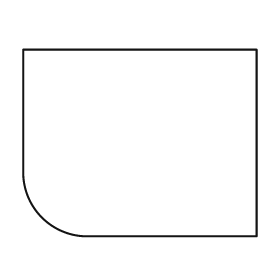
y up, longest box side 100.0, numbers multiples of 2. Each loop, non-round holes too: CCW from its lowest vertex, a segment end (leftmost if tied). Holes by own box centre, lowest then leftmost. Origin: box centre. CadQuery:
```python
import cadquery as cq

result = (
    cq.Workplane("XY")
    .moveTo(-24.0, -40.0)
    .lineTo(50.0, -40.0)
    .lineTo(50.0, 40.0)
    .lineTo(-50.0, 40.0)
    .lineTo(-50.0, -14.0)
    .threePointArc((-42.0, -32.0), (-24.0, -40.0))
    .close()
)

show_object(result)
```